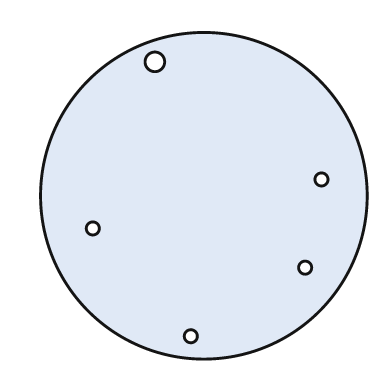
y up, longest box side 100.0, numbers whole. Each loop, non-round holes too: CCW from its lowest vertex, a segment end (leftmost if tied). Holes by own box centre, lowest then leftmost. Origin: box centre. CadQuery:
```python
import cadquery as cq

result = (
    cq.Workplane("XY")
    .moveTo(0.0, 0.0)
    .circle(50.0)
    .moveTo(-4.0, -43.0)
    .circle(2.0)
    .moveTo(31.0, -22.0)
    .circle(2.0)
    .moveTo(-34.0, -10.0)
    .circle(2.0)
    .moveTo(36.0, 5.0)
    .circle(2.0)
    .moveTo(-15.0, 41.0)
    .circle(3.0)
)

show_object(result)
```